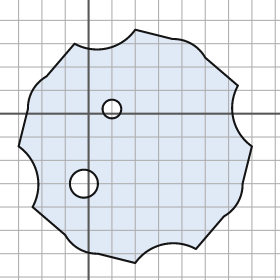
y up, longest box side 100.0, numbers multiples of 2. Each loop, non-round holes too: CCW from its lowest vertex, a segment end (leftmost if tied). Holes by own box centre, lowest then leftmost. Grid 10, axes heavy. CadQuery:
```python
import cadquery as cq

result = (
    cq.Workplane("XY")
    .moveTo(20.0, -64.0)
    .threePointArc((32.0, -56.0), (46.0, -58.0))
    .lineTo(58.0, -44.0)
    .threePointArc((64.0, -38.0), (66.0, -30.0))
    .lineTo(70.0, -14.0)
    .threePointArc((62.0, -2.0), (64.0, 12.0))
    .lineTo(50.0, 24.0)
    .threePointArc((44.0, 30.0), (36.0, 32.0))
    .lineTo(20.0, 36.0)
    .threePointArc((8.0, 28.0), (-6.0, 30.0))
    .lineTo(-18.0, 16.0)
    .threePointArc((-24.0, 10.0), (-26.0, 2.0))
    .lineTo(-30.0, -14.0)
    .threePointArc((-22.0, -26.0), (-24.0, -40.0))
    .lineTo(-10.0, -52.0)
    .threePointArc((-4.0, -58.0), (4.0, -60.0))
    .close()
    .moveTo(-2.0, -30.0)
    .circle(6.0)
    .moveTo(10.0, 2.0)
    .circle(4.0)
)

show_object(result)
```